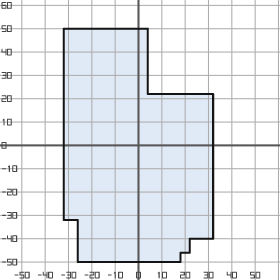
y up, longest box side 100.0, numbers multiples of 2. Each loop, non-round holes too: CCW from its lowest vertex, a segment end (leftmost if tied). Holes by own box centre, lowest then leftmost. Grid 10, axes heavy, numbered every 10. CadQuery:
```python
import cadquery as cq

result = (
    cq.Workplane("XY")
    .moveTo(-26.0, -50.0)
    .lineTo(18.0, -50.0)
    .lineTo(18.0, -46.0)
    .lineTo(22.0, -46.0)
    .lineTo(22.0, -40.0)
    .lineTo(32.0, -40.0)
    .lineTo(32.0, 22.0)
    .lineTo(4.0, 22.0)
    .lineTo(4.0, 50.0)
    .lineTo(-32.0, 50.0)
    .lineTo(-32.0, -32.0)
    .lineTo(-26.0, -32.0)
    .close()
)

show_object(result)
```